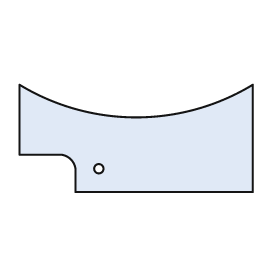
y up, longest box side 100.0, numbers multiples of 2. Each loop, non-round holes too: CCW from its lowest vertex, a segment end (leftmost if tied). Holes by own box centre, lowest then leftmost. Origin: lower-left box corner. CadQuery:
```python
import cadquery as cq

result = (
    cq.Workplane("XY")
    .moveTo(24.0, 0.0)
    .lineTo(100.0, 0.0)
    .lineTo(100.0, 46.0)
    .threePointArc((50.0, 32.0), (0.0, 46.0))
    .lineTo(0.0, 16.0)
    .lineTo(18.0, 16.0)
    .threePointArc((22.0, 14.0), (24.0, 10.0))
    .close()
    .moveTo(34.0, 10.0)
    .circle(2.0)
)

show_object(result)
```